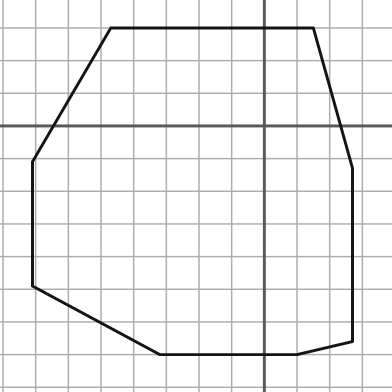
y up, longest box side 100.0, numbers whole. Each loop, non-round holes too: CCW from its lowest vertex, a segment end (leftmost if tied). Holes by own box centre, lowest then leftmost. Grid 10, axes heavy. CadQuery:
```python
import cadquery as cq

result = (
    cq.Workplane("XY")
    .moveTo(-32.0, -70.0)
    .lineTo(10.0, -70.0)
    .lineTo(27.0, -66.0)
    .lineTo(27.0, -13.0)
    .lineTo(15.0, 30.0)
    .lineTo(-47.0, 30.0)
    .lineTo(-71.0, -11.0)
    .lineTo(-71.0, -49.0)
    .close()
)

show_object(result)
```